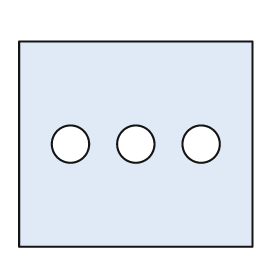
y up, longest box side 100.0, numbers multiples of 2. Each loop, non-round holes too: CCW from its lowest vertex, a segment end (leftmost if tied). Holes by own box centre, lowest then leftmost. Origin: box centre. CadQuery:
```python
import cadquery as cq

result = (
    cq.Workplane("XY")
    .moveTo(-50.0, -44.0)
    .lineTo(50.0, -44.0)
    .lineTo(50.0, 44.0)
    .lineTo(-50.0, 44.0)
    .close()
    .moveTo(-28.0, 0.0)
    .circle(8.0)
    .moveTo(0.0, 0.0)
    .circle(8.0)
    .moveTo(28.0, 0.0)
    .circle(8.0)
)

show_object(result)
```